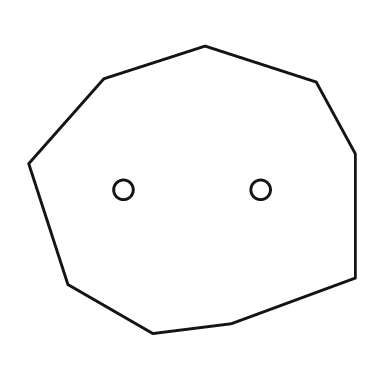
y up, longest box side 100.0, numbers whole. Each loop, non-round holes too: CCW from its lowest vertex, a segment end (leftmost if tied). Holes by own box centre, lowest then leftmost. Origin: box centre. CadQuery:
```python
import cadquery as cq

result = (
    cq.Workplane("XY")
    .moveTo(-12.0, -44.0)
    .lineTo(12.0, -41.0)
    .lineTo(50.0, -27.0)
    .lineTo(50.0, 11.0)
    .lineTo(38.0, 33.0)
    .lineTo(4.0, 44.0)
    .lineTo(-27.0, 34.0)
    .lineTo(-50.0, 8.0)
    .lineTo(-38.0, -29.0)
    .close()
    .moveTo(-21.0, 0.0)
    .circle(3.0)
    .moveTo(21.0, 0.0)
    .circle(3.0)
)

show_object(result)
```